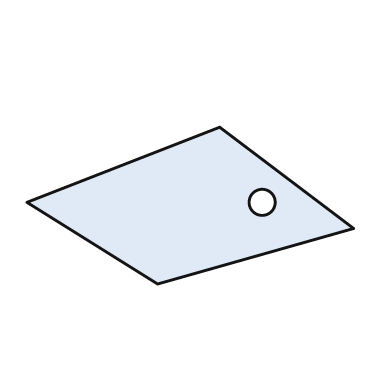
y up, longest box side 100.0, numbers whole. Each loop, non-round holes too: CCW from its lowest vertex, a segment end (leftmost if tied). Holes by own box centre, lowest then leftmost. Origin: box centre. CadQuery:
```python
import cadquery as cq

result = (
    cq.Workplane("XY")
    .moveTo(-10.0, -24.0)
    .lineTo(50.0, -7.0)
    .lineTo(9.0, 24.0)
    .lineTo(-50.0, 1.0)
    .close()
    .moveTo(22.0, 1.0)
    .circle(4.0)
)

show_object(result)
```